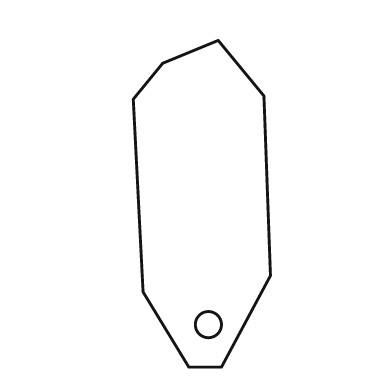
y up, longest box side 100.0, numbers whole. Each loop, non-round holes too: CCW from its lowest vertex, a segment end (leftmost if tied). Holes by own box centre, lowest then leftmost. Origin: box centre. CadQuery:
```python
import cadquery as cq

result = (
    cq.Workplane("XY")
    .moveTo(-4.0, -50.0)
    .lineTo(6.0, -50.0)
    .lineTo(21.0, -22.0)
    .lineTo(19.0, 33.0)
    .lineTo(5.0, 50.0)
    .lineTo(-12.0, 43.0)
    .lineTo(-21.0, 32.0)
    .lineTo(-18.0, -27.0)
    .close()
    .moveTo(2.0, -37.0)
    .circle(4.0)
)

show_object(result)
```